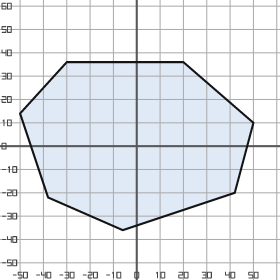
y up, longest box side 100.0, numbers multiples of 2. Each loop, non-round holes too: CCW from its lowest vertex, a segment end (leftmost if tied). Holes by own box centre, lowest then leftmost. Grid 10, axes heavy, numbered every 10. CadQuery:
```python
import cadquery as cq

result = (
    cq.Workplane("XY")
    .moveTo(-6.0, -36.0)
    .lineTo(42.0, -20.0)
    .lineTo(50.0, 10.0)
    .lineTo(20.0, 36.0)
    .lineTo(-30.0, 36.0)
    .lineTo(-50.0, 14.0)
    .lineTo(-38.0, -22.0)
    .close()
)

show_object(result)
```